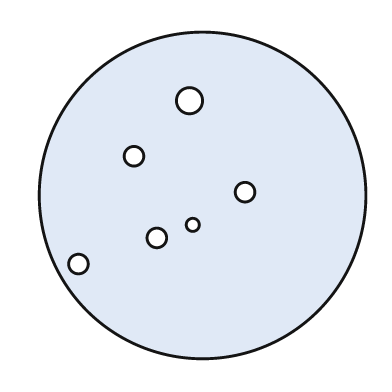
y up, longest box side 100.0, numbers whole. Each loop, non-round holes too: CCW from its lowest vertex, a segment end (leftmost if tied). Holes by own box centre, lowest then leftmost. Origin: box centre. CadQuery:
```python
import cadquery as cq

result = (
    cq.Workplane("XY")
    .moveTo(0.0, 0.0)
    .circle(50.0)
    .moveTo(-38.0, -21.0)
    .circle(3.0)
    .moveTo(-14.0, -13.0)
    .circle(3.0)
    .moveTo(-3.0, -9.0)
    .circle(2.0)
    .moveTo(13.0, 1.0)
    .circle(3.0)
    .moveTo(-21.0, 12.0)
    .circle(3.0)
    .moveTo(-4.0, 29.0)
    .circle(4.0)
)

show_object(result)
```